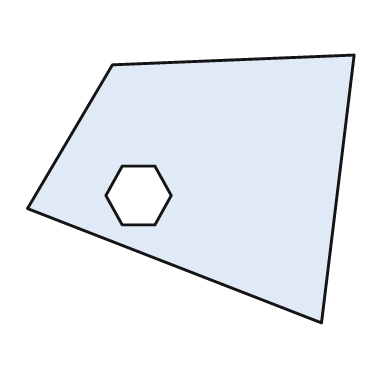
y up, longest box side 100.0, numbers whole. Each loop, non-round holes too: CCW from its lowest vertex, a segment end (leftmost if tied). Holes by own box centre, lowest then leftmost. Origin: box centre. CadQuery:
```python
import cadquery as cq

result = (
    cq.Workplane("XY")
    .moveTo(40.0, -41.0)
    .lineTo(50.0, 41.0)
    .lineTo(-24.0, 38.0)
    .lineTo(-50.0, -6.0)
    .close()
    .moveTo(-21.0, -11.0)
    .lineTo(-11.0, -11.0)
    .lineTo(-6.0, -2.0)
    .lineTo(-11.0, 7.0)
    .lineTo(-21.0, 7.0)
    .lineTo(-26.0, -2.0)
    .close()
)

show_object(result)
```